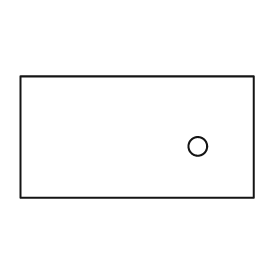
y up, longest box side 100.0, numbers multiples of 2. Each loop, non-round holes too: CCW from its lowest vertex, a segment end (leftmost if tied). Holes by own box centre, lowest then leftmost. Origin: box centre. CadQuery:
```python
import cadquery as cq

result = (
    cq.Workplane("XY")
    .moveTo(-50.0, -26.0)
    .lineTo(50.0, -26.0)
    .lineTo(50.0, 26.0)
    .lineTo(-50.0, 26.0)
    .close()
    .moveTo(26.0, -4.0)
    .circle(4.0)
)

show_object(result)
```